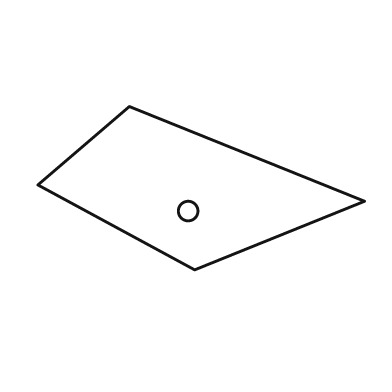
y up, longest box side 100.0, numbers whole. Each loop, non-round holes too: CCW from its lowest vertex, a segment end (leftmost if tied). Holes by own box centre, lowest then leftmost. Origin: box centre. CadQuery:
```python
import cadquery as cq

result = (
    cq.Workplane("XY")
    .moveTo(-2.0, -25.0)
    .lineTo(50.0, -4.0)
    .lineTo(-22.0, 25.0)
    .lineTo(-50.0, 1.0)
    .close()
    .moveTo(-4.0, -7.0)
    .circle(3.0)
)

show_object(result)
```